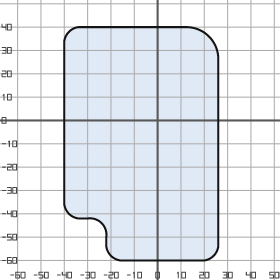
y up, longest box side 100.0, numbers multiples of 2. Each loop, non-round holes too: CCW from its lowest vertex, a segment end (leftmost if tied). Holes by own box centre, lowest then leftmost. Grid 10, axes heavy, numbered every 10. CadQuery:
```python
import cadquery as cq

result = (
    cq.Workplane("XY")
    .moveTo(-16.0, -60.0)
    .lineTo(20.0, -60.0)
    .threePointArc((24.0, -58.0), (26.0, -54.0))
    .lineTo(26.0, 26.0)
    .threePointArc((22.0, 36.0), (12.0, 40.0))
    .lineTo(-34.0, 40.0)
    .threePointArc((-38.0, 38.0), (-40.0, 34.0))
    .lineTo(-40.0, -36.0)
    .threePointArc((-38.0, -40.0), (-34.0, -42.0))
    .lineTo(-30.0, -42.0)
    .threePointArc((-24.0, -44.0), (-22.0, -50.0))
    .lineTo(-22.0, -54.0)
    .threePointArc((-20.0, -58.0), (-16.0, -60.0))
    .close()
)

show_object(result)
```